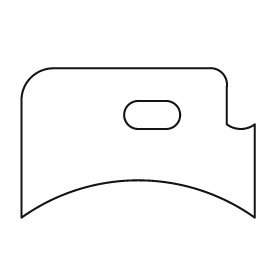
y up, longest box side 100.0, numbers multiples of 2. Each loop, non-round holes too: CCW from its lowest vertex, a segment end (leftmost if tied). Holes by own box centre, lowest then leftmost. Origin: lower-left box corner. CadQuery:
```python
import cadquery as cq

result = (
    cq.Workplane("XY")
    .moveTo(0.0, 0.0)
    .threePointArc((50.0, 16.0), (100.0, 0.0))
    .lineTo(100.0, 40.0)
    .threePointArc((94.0, 38.0), (88.0, 40.0))
    .lineTo(88.0, 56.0)
    .threePointArc((86.0, 62.0), (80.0, 64.0))
    .lineTo(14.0, 64.0)
    .threePointArc((4.0, 60.0), (0.0, 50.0))
    .close()
    .moveTo(50.0, 38.0)
    .lineTo(62.0, 38.0)
    .threePointArc((68.0, 44.0), (62.0, 50.0))
    .lineTo(50.0, 50.0)
    .threePointArc((44.0, 44.0), (50.0, 38.0))
    .close()
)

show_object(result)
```